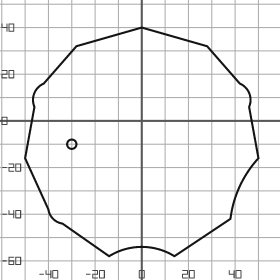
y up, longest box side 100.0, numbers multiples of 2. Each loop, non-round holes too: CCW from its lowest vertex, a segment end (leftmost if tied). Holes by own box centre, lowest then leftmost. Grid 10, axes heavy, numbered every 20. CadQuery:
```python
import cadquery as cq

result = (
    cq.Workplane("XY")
    .moveTo(-14.0, -58.0)
    .threePointArc((0.0, -54.0), (14.0, -58.0))
    .lineTo(38.0, -42.0)
    .threePointArc((42.0, -28.0), (50.0, -16.0))
    .lineTo(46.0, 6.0)
    .threePointArc((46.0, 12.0), (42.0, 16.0))
    .lineTo(28.0, 32.0)
    .lineTo(0.0, 40.0)
    .lineTo(-28.0, 32.0)
    .lineTo(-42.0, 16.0)
    .threePointArc((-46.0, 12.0), (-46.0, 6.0))
    .lineTo(-50.0, -16.0)
    .lineTo(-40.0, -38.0)
    .threePointArc((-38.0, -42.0), (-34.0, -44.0))
    .close()
    .moveTo(-30.0, -10.0)
    .circle(2.0)
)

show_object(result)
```